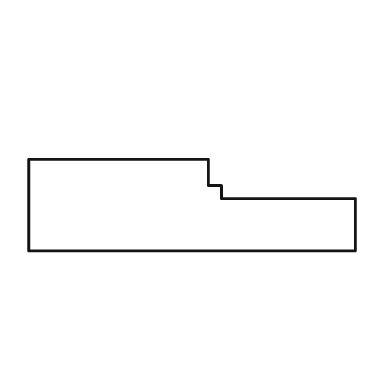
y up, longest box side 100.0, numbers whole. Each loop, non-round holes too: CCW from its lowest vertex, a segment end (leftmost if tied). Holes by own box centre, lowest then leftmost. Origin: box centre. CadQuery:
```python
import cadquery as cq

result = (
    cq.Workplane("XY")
    .moveTo(-50.0, -14.0)
    .lineTo(50.0, -14.0)
    .lineTo(50.0, 2.0)
    .lineTo(9.0, 2.0)
    .lineTo(9.0, 6.0)
    .lineTo(5.0, 6.0)
    .lineTo(5.0, 14.0)
    .lineTo(-50.0, 14.0)
    .close()
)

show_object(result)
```